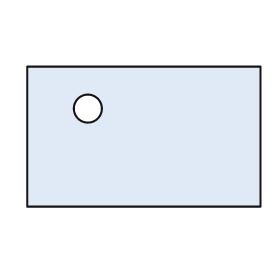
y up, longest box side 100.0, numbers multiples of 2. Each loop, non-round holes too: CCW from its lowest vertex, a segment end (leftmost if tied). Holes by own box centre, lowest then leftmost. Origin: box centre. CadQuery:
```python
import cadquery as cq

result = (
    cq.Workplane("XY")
    .moveTo(-50.0, -30.0)
    .lineTo(50.0, -30.0)
    .lineTo(50.0, 30.0)
    .lineTo(-50.0, 30.0)
    .close()
    .moveTo(-24.0, 12.0)
    .circle(6.0)
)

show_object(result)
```